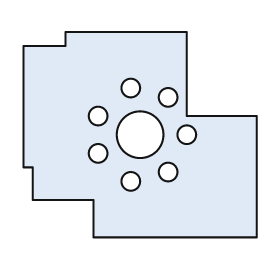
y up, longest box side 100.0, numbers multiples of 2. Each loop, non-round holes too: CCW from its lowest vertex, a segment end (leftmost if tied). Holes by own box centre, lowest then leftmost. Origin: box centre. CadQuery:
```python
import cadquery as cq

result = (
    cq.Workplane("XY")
    .moveTo(-20.0, -44.0)
    .lineTo(50.0, -44.0)
    .lineTo(50.0, 8.0)
    .lineTo(20.0, 8.0)
    .lineTo(20.0, 44.0)
    .lineTo(-32.0, 44.0)
    .lineTo(-32.0, 38.0)
    .lineTo(-50.0, 38.0)
    .lineTo(-50.0, -14.0)
    .lineTo(-46.0, -14.0)
    .lineTo(-46.0, -28.0)
    .lineTo(-20.0, -28.0)
    .close()
    .moveTo(-4.0, -20.0)
    .circle(4.0)
    .moveTo(12.0, -16.0)
    .circle(4.0)
    .moveTo(-18.0, -8.0)
    .circle(4.0)
    .moveTo(0.0, 0.0)
    .circle(10.0)
    .moveTo(20.0, 0.0)
    .circle(4.0)
    .moveTo(-18.0, 8.0)
    .circle(4.0)
    .moveTo(12.0, 16.0)
    .circle(4.0)
    .moveTo(-4.0, 20.0)
    .circle(4.0)
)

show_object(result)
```